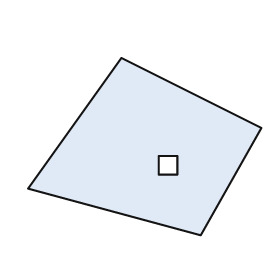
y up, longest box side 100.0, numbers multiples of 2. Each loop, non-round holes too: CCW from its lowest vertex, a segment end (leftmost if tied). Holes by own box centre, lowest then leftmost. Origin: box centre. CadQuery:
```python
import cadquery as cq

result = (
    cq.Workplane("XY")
    .moveTo(24.0, -38.0)
    .lineTo(50.0, 8.0)
    .lineTo(-10.0, 38.0)
    .lineTo(-50.0, -18.0)
    .close()
    .moveTo(6.0, -12.0)
    .lineTo(14.0, -12.0)
    .lineTo(14.0, -4.0)
    .lineTo(6.0, -4.0)
    .close()
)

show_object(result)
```